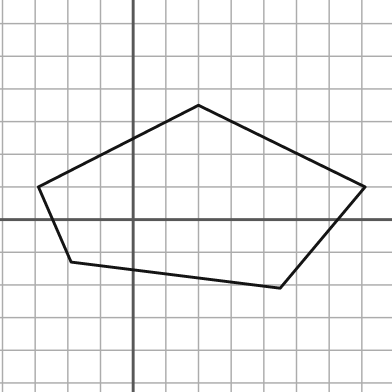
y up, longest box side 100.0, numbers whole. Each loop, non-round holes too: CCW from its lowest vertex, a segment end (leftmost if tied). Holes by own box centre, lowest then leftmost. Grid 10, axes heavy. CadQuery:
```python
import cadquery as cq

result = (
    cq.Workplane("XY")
    .moveTo(45.0, -21.0)
    .lineTo(71.0, 10.0)
    .lineTo(20.0, 35.0)
    .lineTo(-29.0, 10.0)
    .lineTo(-19.0, -13.0)
    .close()
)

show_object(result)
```